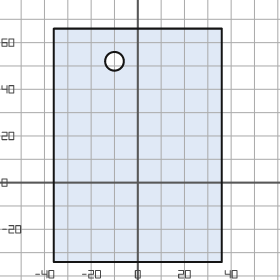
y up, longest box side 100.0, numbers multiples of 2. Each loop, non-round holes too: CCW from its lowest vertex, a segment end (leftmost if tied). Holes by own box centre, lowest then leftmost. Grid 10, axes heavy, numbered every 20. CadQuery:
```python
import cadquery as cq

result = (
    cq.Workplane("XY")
    .moveTo(-36.0, -34.0)
    .lineTo(36.0, -34.0)
    .lineTo(36.0, 66.0)
    .lineTo(-36.0, 66.0)
    .close()
    .moveTo(-10.0, 52.0)
    .circle(4.0)
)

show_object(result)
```